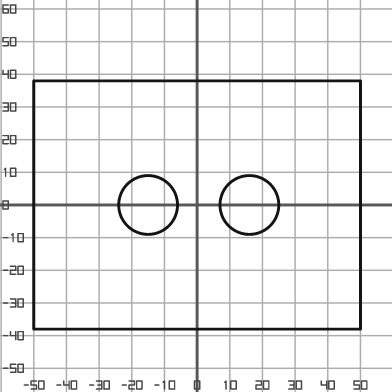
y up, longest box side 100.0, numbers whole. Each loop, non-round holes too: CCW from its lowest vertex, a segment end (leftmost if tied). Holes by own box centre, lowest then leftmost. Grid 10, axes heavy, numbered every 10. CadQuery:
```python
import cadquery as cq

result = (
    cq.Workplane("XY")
    .moveTo(-50.0, -38.0)
    .lineTo(50.0, -38.0)
    .lineTo(50.0, 38.0)
    .lineTo(-50.0, 38.0)
    .close()
    .moveTo(-15.0, 0.0)
    .circle(9.0)
    .moveTo(16.0, 0.0)
    .circle(9.0)
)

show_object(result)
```